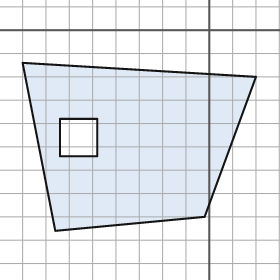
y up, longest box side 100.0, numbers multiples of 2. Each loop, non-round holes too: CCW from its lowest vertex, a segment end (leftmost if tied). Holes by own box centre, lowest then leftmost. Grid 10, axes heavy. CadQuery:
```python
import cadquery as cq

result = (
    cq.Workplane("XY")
    .moveTo(-66.0, -86.0)
    .lineTo(-2.0, -80.0)
    .lineTo(20.0, -20.0)
    .lineTo(-80.0, -14.0)
    .close()
    .moveTo(-64.0, -54.0)
    .lineTo(-48.0, -54.0)
    .lineTo(-48.0, -38.0)
    .lineTo(-64.0, -38.0)
    .close()
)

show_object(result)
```